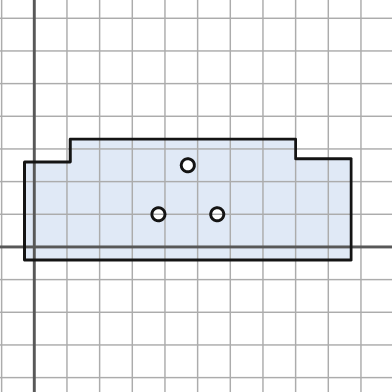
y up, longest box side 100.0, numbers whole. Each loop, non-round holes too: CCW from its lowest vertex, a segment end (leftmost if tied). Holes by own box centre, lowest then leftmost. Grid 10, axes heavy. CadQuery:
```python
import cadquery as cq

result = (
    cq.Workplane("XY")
    .moveTo(-3.0, -4.0)
    .lineTo(97.0, -4.0)
    .lineTo(97.0, 27.0)
    .lineTo(80.0, 27.0)
    .lineTo(80.0, 33.0)
    .lineTo(11.0, 33.0)
    .lineTo(11.0, 26.0)
    .lineTo(-3.0, 26.0)
    .close()
    .moveTo(38.0, 10.0)
    .circle(2.0)
    .moveTo(56.0, 10.0)
    .circle(2.0)
    .moveTo(47.0, 25.0)
    .circle(2.0)
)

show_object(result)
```